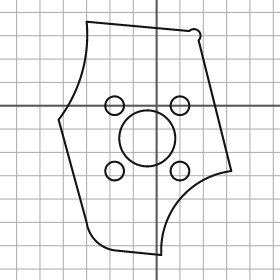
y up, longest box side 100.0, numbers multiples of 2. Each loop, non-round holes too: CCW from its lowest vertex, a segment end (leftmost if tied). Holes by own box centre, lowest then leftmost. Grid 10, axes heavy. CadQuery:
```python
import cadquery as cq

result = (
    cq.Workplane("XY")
    .moveTo(2.0, -64.0)
    .threePointArc((10.0, -40.0), (32.0, -28.0))
    .lineTo(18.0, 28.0)
    .threePointArc((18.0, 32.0), (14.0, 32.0))
    .lineTo(-30.0, 36.0)
    .threePointArc((-32.0, 14.0), (-42.0, -6.0))
    .lineTo(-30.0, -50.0)
    .threePointArc((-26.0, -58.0), (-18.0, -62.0))
    .close()
    .moveTo(-18.0, -28.0)
    .circle(4.0)
    .moveTo(10.0, -28.0)
    .circle(4.0)
    .moveTo(-4.0, -14.0)
    .circle(12.0)
    .moveTo(-18.0, 0.0)
    .circle(4.0)
    .moveTo(10.0, 0.0)
    .circle(4.0)
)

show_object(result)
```